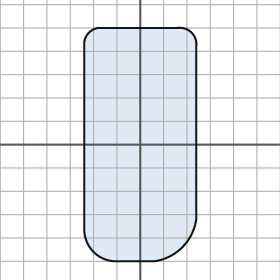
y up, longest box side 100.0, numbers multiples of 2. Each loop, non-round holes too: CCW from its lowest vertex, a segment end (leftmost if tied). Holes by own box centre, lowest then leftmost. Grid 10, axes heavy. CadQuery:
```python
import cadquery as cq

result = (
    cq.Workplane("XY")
    .moveTo(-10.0, -50.0)
    .lineTo(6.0, -50.0)
    .threePointArc((18.0, -44.0), (24.0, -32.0))
    .lineTo(24.0, 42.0)
    .threePointArc((22.0, 48.0), (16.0, 50.0))
    .lineTo(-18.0, 50.0)
    .threePointArc((-22.0, 48.0), (-24.0, 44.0))
    .lineTo(-24.0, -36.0)
    .threePointArc((-20.0, -46.0), (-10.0, -50.0))
    .close()
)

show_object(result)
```